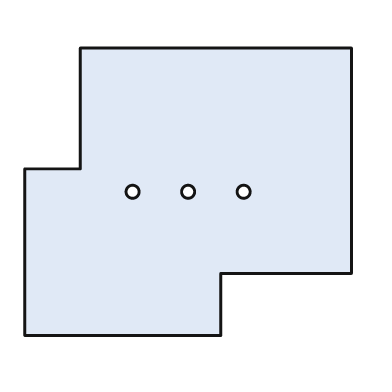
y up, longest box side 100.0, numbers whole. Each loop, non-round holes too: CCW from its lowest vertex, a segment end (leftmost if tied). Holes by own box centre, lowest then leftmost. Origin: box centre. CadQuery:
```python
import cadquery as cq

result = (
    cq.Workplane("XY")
    .moveTo(-50.0, -44.0)
    .lineTo(10.0, -44.0)
    .lineTo(10.0, -25.0)
    .lineTo(50.0, -25.0)
    .lineTo(50.0, 44.0)
    .lineTo(-33.0, 44.0)
    .lineTo(-33.0, 7.0)
    .lineTo(-50.0, 7.0)
    .close()
    .moveTo(-17.0, 0.0)
    .circle(2.0)
    .moveTo(0.0, 0.0)
    .circle(2.0)
    .moveTo(17.0, 0.0)
    .circle(2.0)
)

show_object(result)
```